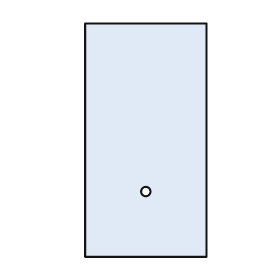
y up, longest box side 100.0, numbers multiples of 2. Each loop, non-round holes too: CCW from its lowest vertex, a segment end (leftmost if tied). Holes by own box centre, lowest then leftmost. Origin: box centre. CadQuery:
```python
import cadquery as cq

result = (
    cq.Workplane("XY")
    .moveTo(-26.0, -50.0)
    .lineTo(26.0, -50.0)
    .lineTo(26.0, 50.0)
    .lineTo(-26.0, 50.0)
    .close()
    .moveTo(0.0, -22.0)
    .circle(2.0)
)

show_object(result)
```